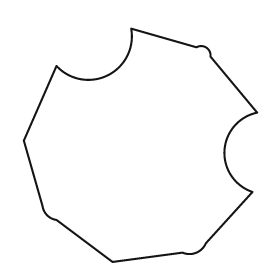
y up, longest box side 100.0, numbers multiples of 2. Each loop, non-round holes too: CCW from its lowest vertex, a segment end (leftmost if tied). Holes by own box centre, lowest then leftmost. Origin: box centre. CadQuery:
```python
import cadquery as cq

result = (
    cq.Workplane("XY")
    .moveTo(-12.0, -50.0)
    .lineTo(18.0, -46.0)
    .threePointArc((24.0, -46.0), (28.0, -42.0))
    .lineTo(48.0, -20.0)
    .threePointArc((36.0, -2.0), (50.0, 14.0))
    .lineTo(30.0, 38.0)
    .threePointArc((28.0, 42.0), (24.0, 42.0))
    .lineTo(-4.0, 50.0)
    .threePointArc((-14.0, 30.0), (-36.0, 34.0))
    .lineTo(-50.0, 2.0)
    .lineTo(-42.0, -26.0)
    .threePointArc((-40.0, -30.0), (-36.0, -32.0))
    .close()
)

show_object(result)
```